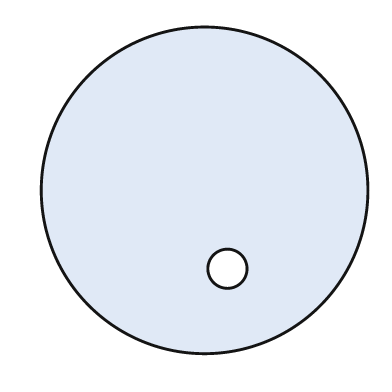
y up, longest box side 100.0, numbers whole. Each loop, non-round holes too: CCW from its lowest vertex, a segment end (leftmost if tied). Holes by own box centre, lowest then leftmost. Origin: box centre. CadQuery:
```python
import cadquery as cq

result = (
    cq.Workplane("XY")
    .moveTo(0.0, 0.0)
    .circle(50.0)
    .moveTo(7.0, -24.0)
    .circle(6.0)
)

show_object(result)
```